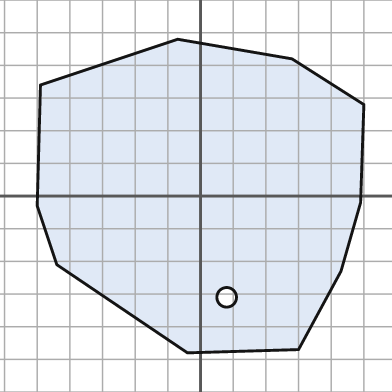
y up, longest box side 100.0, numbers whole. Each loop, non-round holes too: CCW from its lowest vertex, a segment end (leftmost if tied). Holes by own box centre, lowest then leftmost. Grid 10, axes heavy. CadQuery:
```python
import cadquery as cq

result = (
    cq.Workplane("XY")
    .moveTo(-4.0, -48.0)
    .lineTo(30.0, -47.0)
    .lineTo(43.0, -23.0)
    .lineTo(49.0, -2.0)
    .lineTo(50.0, 28.0)
    .lineTo(28.0, 42.0)
    .lineTo(-7.0, 48.0)
    .lineTo(-49.0, 34.0)
    .lineTo(-50.0, -3.0)
    .lineTo(-44.0, -21.0)
    .close()
    .moveTo(8.0, -31.0)
    .circle(3.0)
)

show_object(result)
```